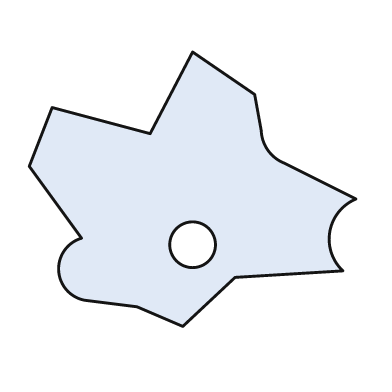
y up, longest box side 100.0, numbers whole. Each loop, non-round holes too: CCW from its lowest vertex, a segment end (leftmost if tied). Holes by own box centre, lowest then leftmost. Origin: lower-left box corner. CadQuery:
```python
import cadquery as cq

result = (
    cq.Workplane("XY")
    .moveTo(47.0, 0.0)
    .lineTo(63.0, 15.0)
    .lineTo(96.0, 17.0)
    .threePointArc((92.0, 29.0), (100.0, 39.0))
    .lineTo(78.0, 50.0)
    .threePointArc((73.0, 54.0), (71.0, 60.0))
    .lineTo(69.0, 71.0)
    .lineTo(50.0, 84.0)
    .lineTo(37.0, 59.0)
    .lineTo(7.0, 67.0)
    .lineTo(0.0, 49.0)
    .lineTo(16.0, 27.0)
    .threePointArc((9.0, 17.0), (17.0, 8.0))
    .lineTo(33.0, 6.0)
    .close()
    .moveTo(50.0, 25.0)
    .circle(7.0)
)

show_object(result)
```